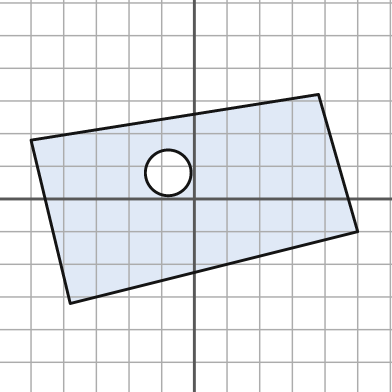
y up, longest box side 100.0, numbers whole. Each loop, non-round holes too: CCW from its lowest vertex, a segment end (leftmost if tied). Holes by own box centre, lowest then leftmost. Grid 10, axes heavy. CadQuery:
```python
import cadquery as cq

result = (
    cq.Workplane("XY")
    .moveTo(-38.0, -32.0)
    .lineTo(50.0, -10.0)
    .lineTo(38.0, 32.0)
    .lineTo(-50.0, 18.0)
    .close()
    .moveTo(-8.0, 8.0)
    .circle(7.0)
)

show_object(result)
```